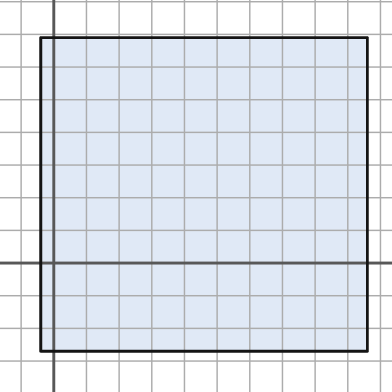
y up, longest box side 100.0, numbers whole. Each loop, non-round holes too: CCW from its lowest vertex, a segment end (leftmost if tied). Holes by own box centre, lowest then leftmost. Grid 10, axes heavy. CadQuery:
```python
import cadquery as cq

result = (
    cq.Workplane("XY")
    .moveTo(-4.0, -27.0)
    .lineTo(96.0, -27.0)
    .lineTo(96.0, 69.0)
    .lineTo(-4.0, 69.0)
    .close()
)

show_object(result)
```